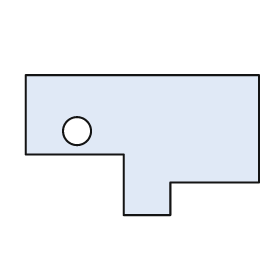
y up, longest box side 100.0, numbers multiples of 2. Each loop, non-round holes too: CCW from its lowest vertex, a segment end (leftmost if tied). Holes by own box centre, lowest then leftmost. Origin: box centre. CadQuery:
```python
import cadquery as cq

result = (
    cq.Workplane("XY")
    .moveTo(-8.0, -30.0)
    .lineTo(12.0, -30.0)
    .lineTo(12.0, -16.0)
    .lineTo(50.0, -16.0)
    .lineTo(50.0, 30.0)
    .lineTo(-50.0, 30.0)
    .lineTo(-50.0, -4.0)
    .lineTo(-8.0, -4.0)
    .close()
    .moveTo(-28.0, 6.0)
    .circle(6.0)
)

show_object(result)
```